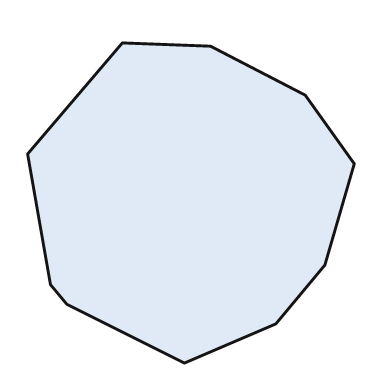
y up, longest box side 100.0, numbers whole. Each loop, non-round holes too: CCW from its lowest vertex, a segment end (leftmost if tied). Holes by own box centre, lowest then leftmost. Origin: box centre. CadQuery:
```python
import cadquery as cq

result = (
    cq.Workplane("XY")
    .moveTo(-2.0, -49.0)
    .lineTo(26.0, -37.0)
    .lineTo(41.0, -19.0)
    .lineTo(50.0, 12.0)
    .lineTo(35.0, 33.0)
    .lineTo(6.0, 48.0)
    .lineTo(-21.0, 49.0)
    .lineTo(-50.0, 15.0)
    .lineTo(-43.0, -25.0)
    .lineTo(-38.0, -31.0)
    .close()
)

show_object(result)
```